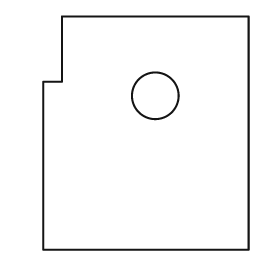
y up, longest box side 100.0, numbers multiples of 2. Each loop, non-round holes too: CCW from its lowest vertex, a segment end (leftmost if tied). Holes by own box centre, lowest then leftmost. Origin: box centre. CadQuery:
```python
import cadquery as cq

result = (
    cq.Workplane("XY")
    .moveTo(-44.0, -50.0)
    .lineTo(44.0, -50.0)
    .lineTo(44.0, 50.0)
    .lineTo(-36.0, 50.0)
    .lineTo(-36.0, 22.0)
    .lineTo(-44.0, 22.0)
    .close()
    .moveTo(4.0, 16.0)
    .circle(10.0)
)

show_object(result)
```